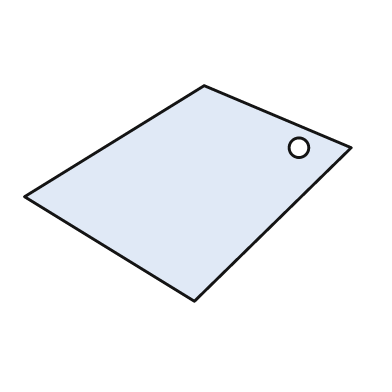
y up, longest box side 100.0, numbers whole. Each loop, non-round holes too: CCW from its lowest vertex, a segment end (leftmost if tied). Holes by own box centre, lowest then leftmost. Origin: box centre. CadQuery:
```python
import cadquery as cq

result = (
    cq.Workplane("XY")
    .moveTo(2.0, -33.0)
    .lineTo(50.0, 14.0)
    .lineTo(5.0, 33.0)
    .lineTo(-50.0, -1.0)
    .close()
    .moveTo(34.0, 14.0)
    .circle(3.0)
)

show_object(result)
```